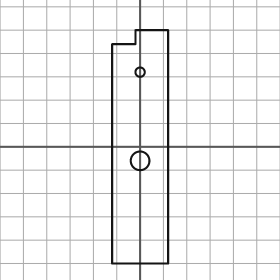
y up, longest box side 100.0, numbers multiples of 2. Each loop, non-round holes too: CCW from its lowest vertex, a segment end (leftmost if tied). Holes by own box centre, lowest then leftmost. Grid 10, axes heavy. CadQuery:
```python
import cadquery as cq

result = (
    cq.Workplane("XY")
    .moveTo(-12.0, -50.0)
    .lineTo(12.0, -50.0)
    .lineTo(12.0, 50.0)
    .lineTo(-2.0, 50.0)
    .lineTo(-2.0, 44.0)
    .lineTo(-12.0, 44.0)
    .close()
    .moveTo(0.0, -6.0)
    .circle(4.0)
    .moveTo(0.0, 32.0)
    .circle(2.0)
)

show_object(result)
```